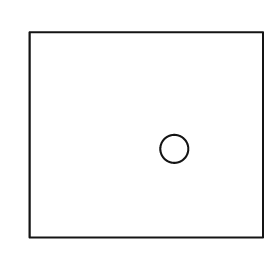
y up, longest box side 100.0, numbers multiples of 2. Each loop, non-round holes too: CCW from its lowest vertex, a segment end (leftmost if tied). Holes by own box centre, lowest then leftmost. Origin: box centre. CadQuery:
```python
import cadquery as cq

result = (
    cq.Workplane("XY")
    .moveTo(-50.0, -44.0)
    .lineTo(50.0, -44.0)
    .lineTo(50.0, 44.0)
    .lineTo(-50.0, 44.0)
    .close()
    .moveTo(12.0, -6.0)
    .circle(6.0)
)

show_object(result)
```